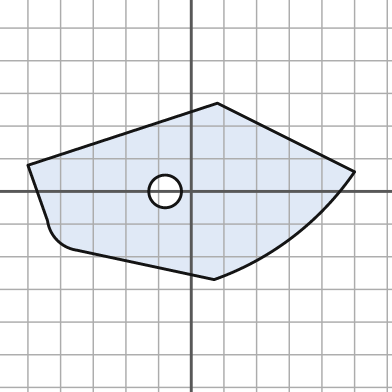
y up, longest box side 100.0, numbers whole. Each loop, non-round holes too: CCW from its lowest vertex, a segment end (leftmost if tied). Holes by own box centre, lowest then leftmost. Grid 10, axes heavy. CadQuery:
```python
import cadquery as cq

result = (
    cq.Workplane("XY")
    .moveTo(7.0, -27.0)
    .threePointArc((31.0, -14.0), (50.0, 6.0))
    .lineTo(8.0, 27.0)
    .lineTo(-50.0, 8.0)
    .lineTo(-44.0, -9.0)
    .threePointArc((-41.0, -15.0), (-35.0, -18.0))
    .close()
    .moveTo(-8.0, 0.0)
    .circle(5.0)
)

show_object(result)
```